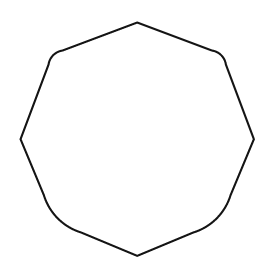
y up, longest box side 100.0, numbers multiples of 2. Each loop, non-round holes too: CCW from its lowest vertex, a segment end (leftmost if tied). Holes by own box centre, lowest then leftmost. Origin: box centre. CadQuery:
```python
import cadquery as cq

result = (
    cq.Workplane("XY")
    .moveTo(0.0, -50.0)
    .lineTo(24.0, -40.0)
    .threePointArc((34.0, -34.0), (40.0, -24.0))
    .lineTo(50.0, 0.0)
    .lineTo(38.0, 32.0)
    .threePointArc((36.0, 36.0), (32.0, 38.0))
    .lineTo(0.0, 50.0)
    .lineTo(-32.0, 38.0)
    .threePointArc((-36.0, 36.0), (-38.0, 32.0))
    .lineTo(-50.0, 0.0)
    .lineTo(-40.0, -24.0)
    .threePointArc((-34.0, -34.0), (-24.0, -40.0))
    .close()
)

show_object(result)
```